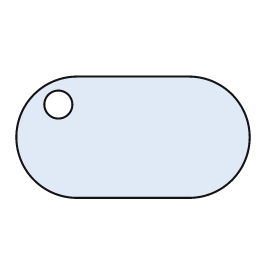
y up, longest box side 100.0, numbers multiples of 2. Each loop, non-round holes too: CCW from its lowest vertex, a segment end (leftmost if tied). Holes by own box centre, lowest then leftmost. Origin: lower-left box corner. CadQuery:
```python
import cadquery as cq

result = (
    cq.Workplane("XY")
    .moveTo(26.0, 0.0)
    .lineTo(74.0, 0.0)
    .threePointArc((100.0, 26.0), (74.0, 52.0))
    .lineTo(26.0, 52.0)
    .threePointArc((0.0, 26.0), (26.0, 0.0))
    .close()
    .moveTo(18.0, 40.0)
    .circle(6.0)
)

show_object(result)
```